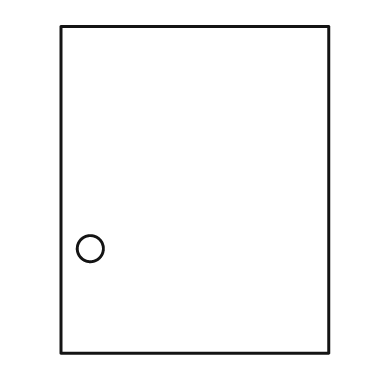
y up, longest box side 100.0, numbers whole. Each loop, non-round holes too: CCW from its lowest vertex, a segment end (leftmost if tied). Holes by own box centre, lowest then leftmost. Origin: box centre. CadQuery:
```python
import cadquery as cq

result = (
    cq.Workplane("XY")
    .moveTo(-41.0, -50.0)
    .lineTo(41.0, -50.0)
    .lineTo(41.0, 50.0)
    .lineTo(-41.0, 50.0)
    .close()
    .moveTo(-32.0, -18.0)
    .circle(4.0)
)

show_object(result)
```